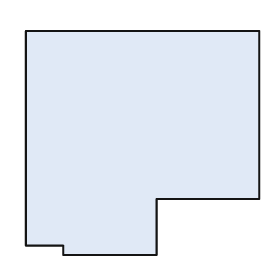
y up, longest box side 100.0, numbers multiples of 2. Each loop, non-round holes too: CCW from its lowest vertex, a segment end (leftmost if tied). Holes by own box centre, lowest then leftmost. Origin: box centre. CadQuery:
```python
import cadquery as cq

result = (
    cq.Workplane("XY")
    .moveTo(-34.0, -48.0)
    .lineTo(6.0, -48.0)
    .lineTo(6.0, -24.0)
    .lineTo(50.0, -24.0)
    .lineTo(50.0, 48.0)
    .lineTo(-50.0, 48.0)
    .lineTo(-50.0, -44.0)
    .lineTo(-34.0, -44.0)
    .close()
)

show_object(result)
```